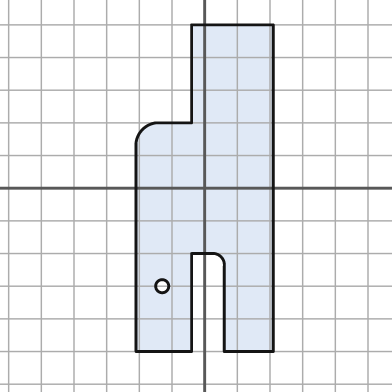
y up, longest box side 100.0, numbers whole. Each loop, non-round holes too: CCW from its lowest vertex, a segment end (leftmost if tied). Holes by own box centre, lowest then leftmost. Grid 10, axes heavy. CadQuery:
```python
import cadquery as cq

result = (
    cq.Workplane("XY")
    .moveTo(-21.0, -50.0)
    .lineTo(-4.0, -50.0)
    .lineTo(-4.0, -20.0)
    .lineTo(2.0, -20.0)
    .threePointArc((5.0, -21.0), (6.0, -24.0))
    .lineTo(6.0, -50.0)
    .lineTo(21.0, -50.0)
    .lineTo(21.0, 50.0)
    .lineTo(-4.0, 50.0)
    .lineTo(-4.0, 20.0)
    .lineTo(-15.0, 20.0)
    .threePointArc((-19.0, 18.0), (-21.0, 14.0))
    .close()
    .moveTo(-13.0, -30.0)
    .circle(2.0)
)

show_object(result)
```